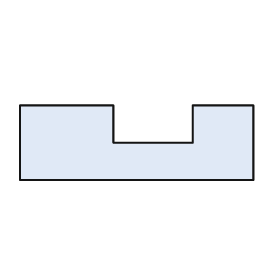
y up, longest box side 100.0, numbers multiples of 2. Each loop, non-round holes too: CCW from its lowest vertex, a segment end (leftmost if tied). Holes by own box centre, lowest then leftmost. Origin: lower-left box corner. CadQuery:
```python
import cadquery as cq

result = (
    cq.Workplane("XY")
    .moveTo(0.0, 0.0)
    .lineTo(100.0, 0.0)
    .lineTo(100.0, 32.0)
    .lineTo(74.0, 32.0)
    .lineTo(74.0, 16.0)
    .lineTo(40.0, 16.0)
    .lineTo(40.0, 32.0)
    .lineTo(0.0, 32.0)
    .close()
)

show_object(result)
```